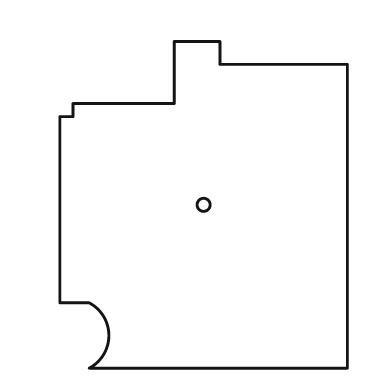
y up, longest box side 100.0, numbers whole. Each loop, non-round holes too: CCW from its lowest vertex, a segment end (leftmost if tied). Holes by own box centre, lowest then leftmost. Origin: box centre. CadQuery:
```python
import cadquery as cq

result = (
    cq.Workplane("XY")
    .moveTo(-35.0, -50.0)
    .lineTo(44.0, -50.0)
    .lineTo(44.0, 43.0)
    .lineTo(5.0, 43.0)
    .lineTo(5.0, 50.0)
    .lineTo(-9.0, 50.0)
    .lineTo(-9.0, 31.0)
    .lineTo(-40.0, 31.0)
    .lineTo(-40.0, 27.0)
    .lineTo(-44.0, 27.0)
    .lineTo(-44.0, -30.0)
    .lineTo(-35.0, -30.0)
    .threePointArc((-29.0, -40.0), (-35.0, -50.0))
    .close()
    .moveTo(0.0, 0.0)
    .circle(2.0)
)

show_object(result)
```